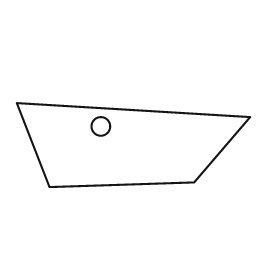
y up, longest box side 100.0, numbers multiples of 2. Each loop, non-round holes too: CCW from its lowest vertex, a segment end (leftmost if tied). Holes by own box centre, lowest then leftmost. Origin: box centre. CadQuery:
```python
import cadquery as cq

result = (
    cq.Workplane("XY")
    .moveTo(-36.0, -18.0)
    .lineTo(26.0, -16.0)
    .lineTo(50.0, 12.0)
    .lineTo(-50.0, 18.0)
    .close()
    .moveTo(-14.0, 8.0)
    .circle(4.0)
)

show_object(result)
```